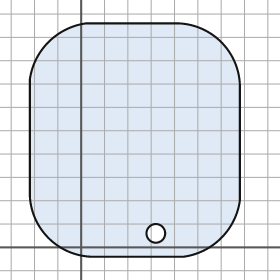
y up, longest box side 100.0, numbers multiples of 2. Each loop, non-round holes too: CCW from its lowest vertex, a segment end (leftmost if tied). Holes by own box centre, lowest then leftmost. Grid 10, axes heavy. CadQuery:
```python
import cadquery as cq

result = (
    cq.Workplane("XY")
    .moveTo(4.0, -4.0)
    .lineTo(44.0, -4.0)
    .threePointArc((60.0, 4.0), (68.0, 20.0))
    .lineTo(68.0, 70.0)
    .threePointArc((60.0, 88.0), (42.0, 96.0))
    .lineTo(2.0, 96.0)
    .threePointArc((-14.0, 88.0), (-22.0, 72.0))
    .lineTo(-22.0, 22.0)
    .threePointArc((-14.0, 4.0), (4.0, -4.0))
    .close()
    .moveTo(32.0, 6.0)
    .circle(4.0)
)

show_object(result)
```